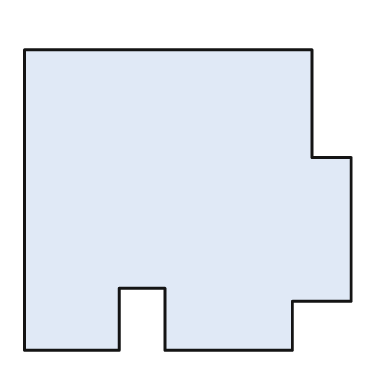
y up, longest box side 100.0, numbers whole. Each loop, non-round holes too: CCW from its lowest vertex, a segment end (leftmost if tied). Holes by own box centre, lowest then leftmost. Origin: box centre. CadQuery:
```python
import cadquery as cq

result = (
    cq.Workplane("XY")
    .moveTo(-50.0, -46.0)
    .lineTo(-21.0, -46.0)
    .lineTo(-21.0, -27.0)
    .lineTo(-7.0, -27.0)
    .lineTo(-7.0, -46.0)
    .lineTo(32.0, -46.0)
    .lineTo(32.0, -31.0)
    .lineTo(50.0, -31.0)
    .lineTo(50.0, 13.0)
    .lineTo(38.0, 13.0)
    .lineTo(38.0, 46.0)
    .lineTo(-50.0, 46.0)
    .close()
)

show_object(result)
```